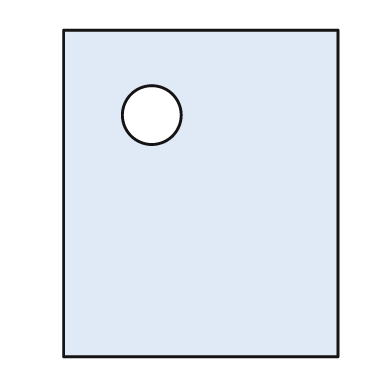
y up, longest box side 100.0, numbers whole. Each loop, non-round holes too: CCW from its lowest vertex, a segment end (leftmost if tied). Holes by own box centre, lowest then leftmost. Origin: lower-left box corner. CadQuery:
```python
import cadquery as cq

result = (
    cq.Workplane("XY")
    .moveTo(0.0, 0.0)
    .lineTo(84.0, 0.0)
    .lineTo(84.0, 100.0)
    .lineTo(0.0, 100.0)
    .close()
    .moveTo(27.0, 74.0)
    .circle(9.0)
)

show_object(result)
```